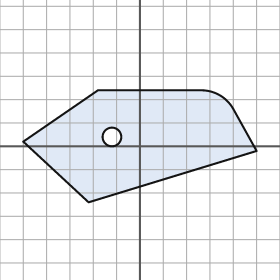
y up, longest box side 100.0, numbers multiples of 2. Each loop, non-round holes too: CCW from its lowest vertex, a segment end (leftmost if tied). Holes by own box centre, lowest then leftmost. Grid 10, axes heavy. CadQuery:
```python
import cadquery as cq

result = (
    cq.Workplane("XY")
    .moveTo(-22.0, -24.0)
    .lineTo(50.0, -2.0)
    .lineTo(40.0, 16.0)
    .threePointArc((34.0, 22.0), (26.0, 24.0))
    .lineTo(-18.0, 24.0)
    .lineTo(-50.0, 2.0)
    .close()
    .moveTo(-12.0, 4.0)
    .circle(4.0)
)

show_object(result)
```